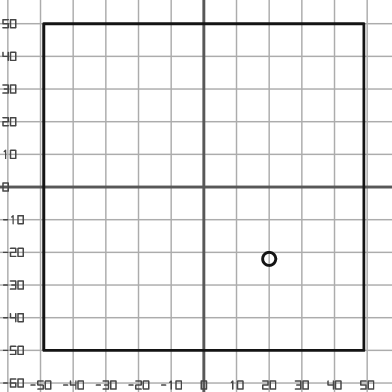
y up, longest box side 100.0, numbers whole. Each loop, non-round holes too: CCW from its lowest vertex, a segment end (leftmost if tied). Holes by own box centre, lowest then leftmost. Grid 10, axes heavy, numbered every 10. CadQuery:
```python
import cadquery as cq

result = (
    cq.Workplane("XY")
    .moveTo(-49.0, -50.0)
    .lineTo(49.0, -50.0)
    .lineTo(49.0, 50.0)
    .lineTo(-49.0, 50.0)
    .close()
    .moveTo(20.0, -22.0)
    .circle(2.0)
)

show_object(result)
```